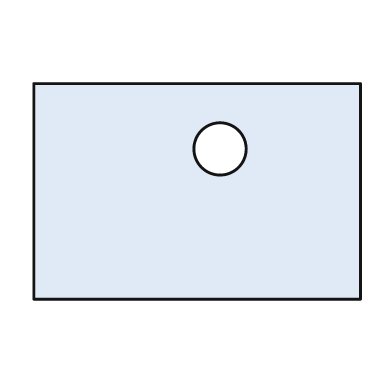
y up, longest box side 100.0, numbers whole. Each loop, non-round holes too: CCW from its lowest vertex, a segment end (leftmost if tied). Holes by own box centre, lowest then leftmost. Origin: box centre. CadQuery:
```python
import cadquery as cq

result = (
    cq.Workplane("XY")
    .moveTo(-50.0, -33.0)
    .lineTo(50.0, -33.0)
    .lineTo(50.0, 33.0)
    .lineTo(-50.0, 33.0)
    .close()
    .moveTo(7.0, 13.0)
    .circle(8.0)
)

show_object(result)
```